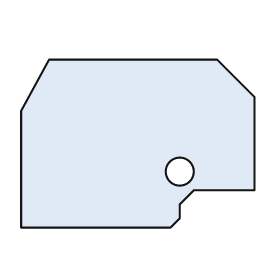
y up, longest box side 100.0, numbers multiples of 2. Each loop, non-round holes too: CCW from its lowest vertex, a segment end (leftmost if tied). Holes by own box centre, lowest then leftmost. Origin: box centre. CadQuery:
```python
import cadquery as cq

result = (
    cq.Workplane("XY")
    .moveTo(-50.0, -36.0)
    .lineTo(14.0, -36.0)
    .lineTo(18.0, -32.0)
    .lineTo(18.0, -26.0)
    .lineTo(24.0, -20.0)
    .lineTo(50.0, -20.0)
    .lineTo(50.0, 20.0)
    .lineTo(34.0, 36.0)
    .lineTo(-38.0, 36.0)
    .lineTo(-50.0, 14.0)
    .close()
    .moveTo(18.0, -12.0)
    .circle(6.0)
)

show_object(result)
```